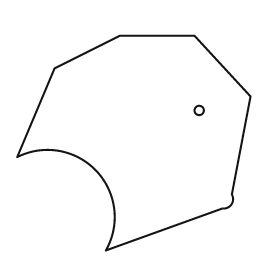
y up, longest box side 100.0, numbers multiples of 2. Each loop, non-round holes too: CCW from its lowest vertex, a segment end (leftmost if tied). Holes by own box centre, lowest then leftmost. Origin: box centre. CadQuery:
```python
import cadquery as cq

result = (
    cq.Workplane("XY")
    .moveTo(-12.0, -46.0)
    .lineTo(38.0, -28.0)
    .threePointArc((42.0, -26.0), (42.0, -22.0))
    .lineTo(50.0, 20.0)
    .lineTo(26.0, 46.0)
    .lineTo(-6.0, 46.0)
    .lineTo(-34.0, 32.0)
    .lineTo(-50.0, -6.0)
    .threePointArc((-16.0, -12.0), (-12.0, -46.0))
    .close()
    .moveTo(28.0, 14.0)
    .circle(2.0)
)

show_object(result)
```